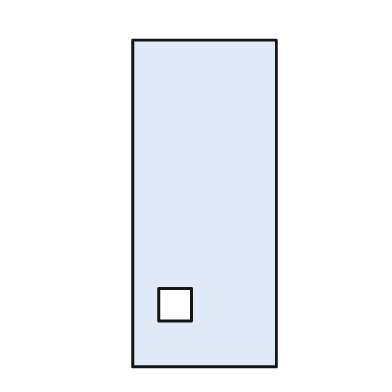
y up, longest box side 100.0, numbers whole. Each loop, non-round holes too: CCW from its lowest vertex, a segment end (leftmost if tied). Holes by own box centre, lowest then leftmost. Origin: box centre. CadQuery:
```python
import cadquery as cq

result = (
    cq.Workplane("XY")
    .moveTo(-22.0, -50.0)
    .lineTo(22.0, -50.0)
    .lineTo(22.0, 50.0)
    .lineTo(-22.0, 50.0)
    .close()
    .moveTo(-14.0, -36.0)
    .lineTo(-4.0, -36.0)
    .lineTo(-4.0, -26.0)
    .lineTo(-14.0, -26.0)
    .close()
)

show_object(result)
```